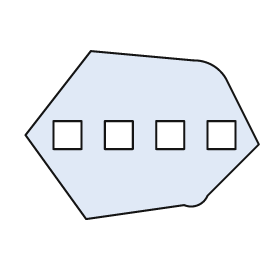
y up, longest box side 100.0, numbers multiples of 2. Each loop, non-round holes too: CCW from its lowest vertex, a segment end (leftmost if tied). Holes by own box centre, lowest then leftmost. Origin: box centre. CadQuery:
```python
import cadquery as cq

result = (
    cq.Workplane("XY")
    .moveTo(-24.0, -36.0)
    .lineTo(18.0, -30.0)
    .threePointArc((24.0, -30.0), (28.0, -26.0))
    .lineTo(50.0, -4.0)
    .lineTo(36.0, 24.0)
    .threePointArc((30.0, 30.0), (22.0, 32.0))
    .lineTo(-22.0, 36.0)
    .lineTo(-50.0, 0.0)
    .close()
    .moveTo(-38.0, -6.0)
    .lineTo(-26.0, -6.0)
    .lineTo(-26.0, 6.0)
    .lineTo(-38.0, 6.0)
    .close()
    .moveTo(-16.0, -6.0)
    .lineTo(-4.0, -6.0)
    .lineTo(-4.0, 6.0)
    .lineTo(-16.0, 6.0)
    .close()
    .moveTo(6.0, -6.0)
    .lineTo(18.0, -6.0)
    .lineTo(18.0, 6.0)
    .lineTo(6.0, 6.0)
    .close()
    .moveTo(28.0, -6.0)
    .lineTo(40.0, -6.0)
    .lineTo(40.0, 6.0)
    .lineTo(28.0, 6.0)
    .close()
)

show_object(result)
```